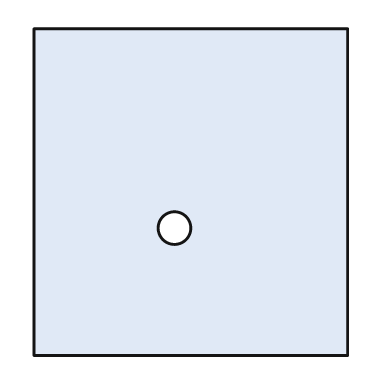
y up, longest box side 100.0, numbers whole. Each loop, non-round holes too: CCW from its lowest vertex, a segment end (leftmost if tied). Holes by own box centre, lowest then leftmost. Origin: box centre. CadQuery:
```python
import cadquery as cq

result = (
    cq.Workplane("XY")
    .moveTo(-48.0, -50.0)
    .lineTo(48.0, -50.0)
    .lineTo(48.0, 50.0)
    .lineTo(-48.0, 50.0)
    .close()
    .moveTo(-5.0, -11.0)
    .circle(5.0)
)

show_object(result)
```